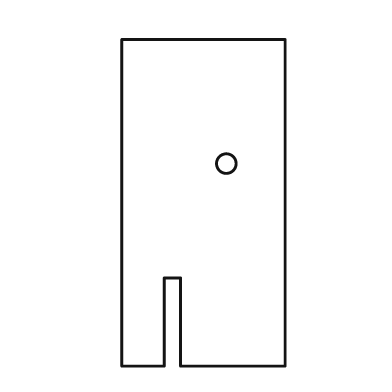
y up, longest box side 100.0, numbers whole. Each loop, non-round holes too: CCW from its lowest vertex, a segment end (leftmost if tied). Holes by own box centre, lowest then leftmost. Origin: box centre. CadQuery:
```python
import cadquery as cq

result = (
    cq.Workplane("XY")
    .moveTo(-25.0, -50.0)
    .lineTo(-12.0, -50.0)
    .lineTo(-12.0, -23.0)
    .lineTo(-7.0, -23.0)
    .lineTo(-7.0, -50.0)
    .lineTo(25.0, -50.0)
    .lineTo(25.0, 50.0)
    .lineTo(-25.0, 50.0)
    .close()
    .moveTo(7.0, 12.0)
    .circle(3.0)
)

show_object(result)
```